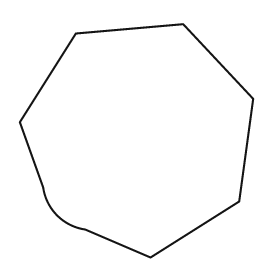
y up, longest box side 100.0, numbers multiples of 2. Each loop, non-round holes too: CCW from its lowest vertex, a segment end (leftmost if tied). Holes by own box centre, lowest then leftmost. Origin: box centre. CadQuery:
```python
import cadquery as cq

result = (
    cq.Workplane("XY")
    .moveTo(6.0, -50.0)
    .lineTo(44.0, -26.0)
    .lineTo(50.0, 18.0)
    .lineTo(20.0, 50.0)
    .lineTo(-26.0, 46.0)
    .lineTo(-50.0, 8.0)
    .lineTo(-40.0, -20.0)
    .threePointArc((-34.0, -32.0), (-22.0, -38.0))
    .close()
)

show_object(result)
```